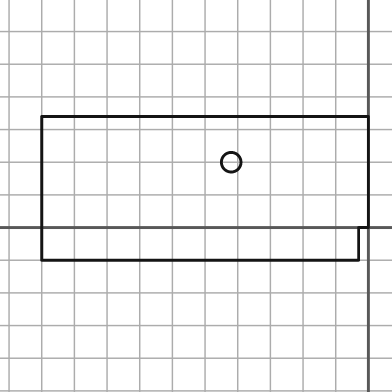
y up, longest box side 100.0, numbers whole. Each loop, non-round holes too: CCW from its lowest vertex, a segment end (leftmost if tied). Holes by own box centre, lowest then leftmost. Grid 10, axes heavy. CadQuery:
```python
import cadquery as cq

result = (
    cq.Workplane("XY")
    .moveTo(-100.0, -10.0)
    .lineTo(-3.0, -10.0)
    .lineTo(-3.0, 0.0)
    .lineTo(0.0, 0.0)
    .lineTo(0.0, 34.0)
    .lineTo(-100.0, 34.0)
    .close()
    .moveTo(-42.0, 20.0)
    .circle(3.0)
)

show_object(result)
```